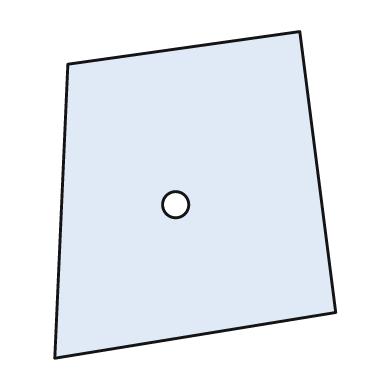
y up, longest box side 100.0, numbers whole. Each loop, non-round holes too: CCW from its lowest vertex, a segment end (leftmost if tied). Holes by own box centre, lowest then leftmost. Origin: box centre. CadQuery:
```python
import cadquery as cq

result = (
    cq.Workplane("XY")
    .moveTo(-43.0, -50.0)
    .lineTo(43.0, -36.0)
    .lineTo(32.0, 50.0)
    .lineTo(-39.0, 40.0)
    .close()
    .moveTo(-6.0, -3.0)
    .circle(4.0)
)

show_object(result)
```